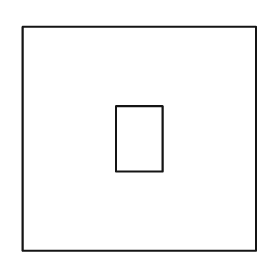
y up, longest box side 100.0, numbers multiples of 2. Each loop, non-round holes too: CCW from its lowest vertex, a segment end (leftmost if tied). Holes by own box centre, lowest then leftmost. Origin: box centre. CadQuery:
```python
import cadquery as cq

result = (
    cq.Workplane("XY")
    .moveTo(-50.0, -48.0)
    .lineTo(50.0, -48.0)
    .lineTo(50.0, 48.0)
    .lineTo(-50.0, 48.0)
    .close()
    .moveTo(-10.0, -14.0)
    .lineTo(10.0, -14.0)
    .lineTo(10.0, 14.0)
    .lineTo(-10.0, 14.0)
    .close()
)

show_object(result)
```